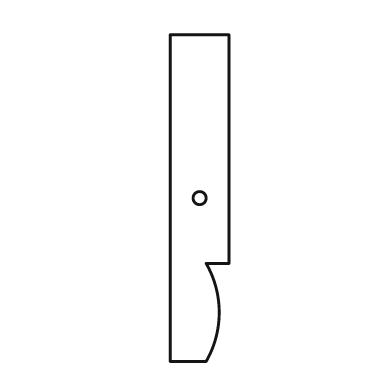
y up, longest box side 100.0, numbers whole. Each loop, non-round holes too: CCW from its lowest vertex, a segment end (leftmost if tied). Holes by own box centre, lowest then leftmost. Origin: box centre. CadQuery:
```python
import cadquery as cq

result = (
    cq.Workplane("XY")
    .moveTo(-9.0, -50.0)
    .lineTo(2.0, -50.0)
    .threePointArc((6.0, -35.0), (2.0, -20.0))
    .lineTo(9.0, -20.0)
    .lineTo(9.0, 50.0)
    .lineTo(-9.0, 50.0)
    .close()
    .moveTo(0.0, 0.0)
    .circle(2.0)
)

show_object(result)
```